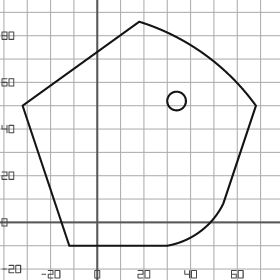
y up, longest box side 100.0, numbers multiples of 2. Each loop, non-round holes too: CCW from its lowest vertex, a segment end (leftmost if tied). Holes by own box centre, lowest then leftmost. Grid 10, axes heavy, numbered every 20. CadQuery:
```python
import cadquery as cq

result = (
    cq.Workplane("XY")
    .moveTo(-12.0, -10.0)
    .lineTo(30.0, -10.0)
    .threePointArc((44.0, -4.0), (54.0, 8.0))
    .lineTo(68.0, 50.0)
    .threePointArc((46.0, 72.0), (18.0, 86.0))
    .lineTo(-32.0, 50.0)
    .close()
    .moveTo(34.0, 52.0)
    .circle(4.0)
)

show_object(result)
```